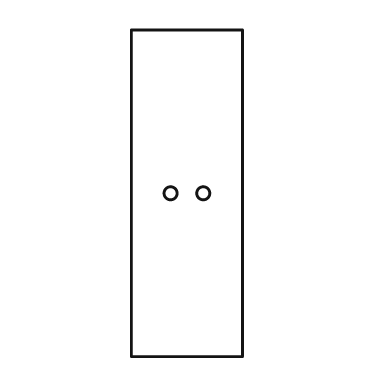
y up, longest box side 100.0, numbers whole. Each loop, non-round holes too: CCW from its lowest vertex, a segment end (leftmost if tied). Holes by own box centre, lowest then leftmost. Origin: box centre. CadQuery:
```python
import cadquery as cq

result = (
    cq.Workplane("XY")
    .moveTo(-17.0, -50.0)
    .lineTo(17.0, -50.0)
    .lineTo(17.0, 50.0)
    .lineTo(-17.0, 50.0)
    .close()
    .moveTo(-5.0, 0.0)
    .circle(2.0)
    .moveTo(5.0, 0.0)
    .circle(2.0)
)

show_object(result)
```